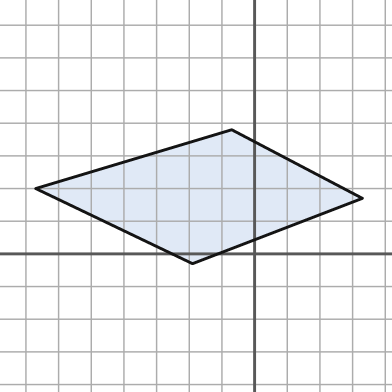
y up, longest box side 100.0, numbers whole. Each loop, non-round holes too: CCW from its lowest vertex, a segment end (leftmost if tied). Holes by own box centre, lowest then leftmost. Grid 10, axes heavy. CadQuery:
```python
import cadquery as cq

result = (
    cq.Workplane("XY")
    .moveTo(-19.0, -3.0)
    .lineTo(33.0, 17.0)
    .lineTo(-7.0, 38.0)
    .lineTo(-67.0, 20.0)
    .close()
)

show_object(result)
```